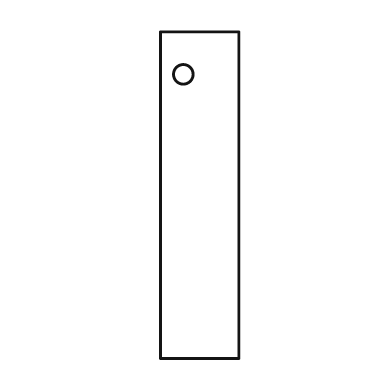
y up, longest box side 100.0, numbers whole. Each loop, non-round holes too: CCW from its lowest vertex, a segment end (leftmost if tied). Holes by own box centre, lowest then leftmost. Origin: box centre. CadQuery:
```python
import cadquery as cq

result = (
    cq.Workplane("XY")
    .moveTo(-12.0, -50.0)
    .lineTo(12.0, -50.0)
    .lineTo(12.0, 50.0)
    .lineTo(-12.0, 50.0)
    .close()
    .moveTo(-5.0, 37.0)
    .circle(3.0)
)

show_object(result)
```